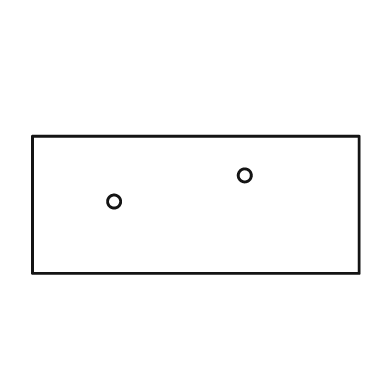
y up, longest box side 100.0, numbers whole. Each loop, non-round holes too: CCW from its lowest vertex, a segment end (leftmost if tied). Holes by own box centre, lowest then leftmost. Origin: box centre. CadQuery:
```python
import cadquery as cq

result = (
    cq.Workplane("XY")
    .moveTo(-50.0, -21.0)
    .lineTo(50.0, -21.0)
    .lineTo(50.0, 21.0)
    .lineTo(-50.0, 21.0)
    .close()
    .moveTo(-25.0, 1.0)
    .circle(2.0)
    .moveTo(15.0, 9.0)
    .circle(2.0)
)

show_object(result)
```